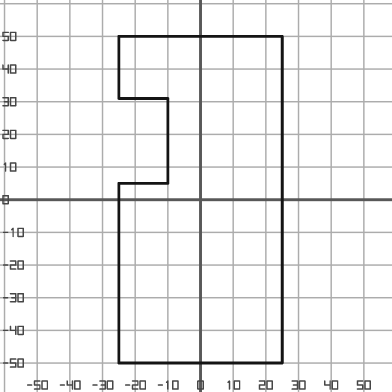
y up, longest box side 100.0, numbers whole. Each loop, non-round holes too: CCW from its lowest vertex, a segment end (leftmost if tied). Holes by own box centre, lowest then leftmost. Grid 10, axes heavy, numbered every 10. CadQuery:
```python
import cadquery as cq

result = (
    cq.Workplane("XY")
    .moveTo(-25.0, -50.0)
    .lineTo(25.0, -50.0)
    .lineTo(25.0, 50.0)
    .lineTo(-25.0, 50.0)
    .lineTo(-25.0, 31.0)
    .lineTo(-10.0, 31.0)
    .lineTo(-10.0, 5.0)
    .lineTo(-25.0, 5.0)
    .close()
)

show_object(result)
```